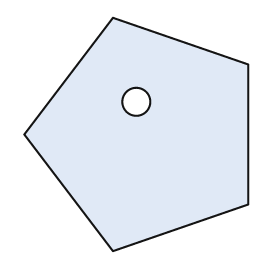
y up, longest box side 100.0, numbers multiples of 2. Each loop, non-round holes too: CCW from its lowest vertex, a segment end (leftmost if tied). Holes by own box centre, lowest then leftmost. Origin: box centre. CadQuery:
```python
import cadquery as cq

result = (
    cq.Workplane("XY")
    .moveTo(-10.0, -50.0)
    .lineTo(48.0, -30.0)
    .lineTo(48.0, 30.0)
    .lineTo(-10.0, 50.0)
    .lineTo(-48.0, 0.0)
    .close()
    .moveTo(0.0, 14.0)
    .circle(6.0)
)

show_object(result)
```